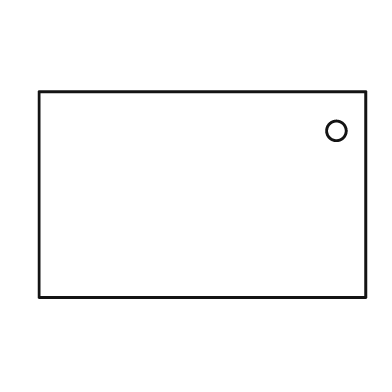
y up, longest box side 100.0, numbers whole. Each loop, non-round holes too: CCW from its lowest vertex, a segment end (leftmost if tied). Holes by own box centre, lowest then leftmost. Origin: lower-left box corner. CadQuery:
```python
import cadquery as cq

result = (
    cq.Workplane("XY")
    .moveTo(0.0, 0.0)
    .lineTo(100.0, 0.0)
    .lineTo(100.0, 63.0)
    .lineTo(0.0, 63.0)
    .close()
    .moveTo(91.0, 51.0)
    .circle(3.0)
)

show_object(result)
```